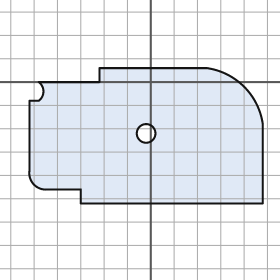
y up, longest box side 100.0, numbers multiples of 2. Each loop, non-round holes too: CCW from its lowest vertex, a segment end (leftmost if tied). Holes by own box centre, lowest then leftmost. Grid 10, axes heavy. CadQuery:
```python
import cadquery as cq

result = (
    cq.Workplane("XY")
    .moveTo(-30.0, -52.0)
    .lineTo(48.0, -52.0)
    .lineTo(48.0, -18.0)
    .threePointArc((40.0, -2.0), (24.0, 6.0))
    .lineTo(-22.0, 6.0)
    .lineTo(-22.0, 0.0)
    .lineTo(-48.0, 0.0)
    .threePointArc((-46.0, -4.0), (-48.0, -8.0))
    .lineTo(-52.0, -8.0)
    .lineTo(-52.0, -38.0)
    .threePointArc((-50.0, -44.0), (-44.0, -46.0))
    .lineTo(-30.0, -46.0)
    .close()
    .moveTo(-2.0, -22.0)
    .circle(4.0)
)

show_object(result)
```